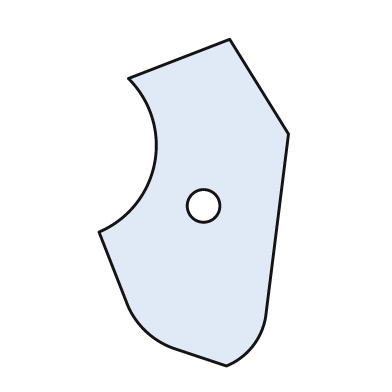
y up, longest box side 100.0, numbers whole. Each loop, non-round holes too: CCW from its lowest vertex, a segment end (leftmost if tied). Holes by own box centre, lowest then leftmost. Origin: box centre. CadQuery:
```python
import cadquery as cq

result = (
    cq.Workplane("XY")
    .moveTo(10.0, -50.0)
    .threePointArc((18.0, -44.0), (22.0, -35.0))
    .lineTo(29.0, 21.0)
    .lineTo(11.0, 50.0)
    .lineTo(-20.0, 38.0)
    .threePointArc((-12.0, 12.0), (-29.0, -9.0))
    .lineTo(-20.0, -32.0)
    .threePointArc((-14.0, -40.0), (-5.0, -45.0))
    .close()
    .moveTo(3.0, -1.0)
    .circle(5.0)
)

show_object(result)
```